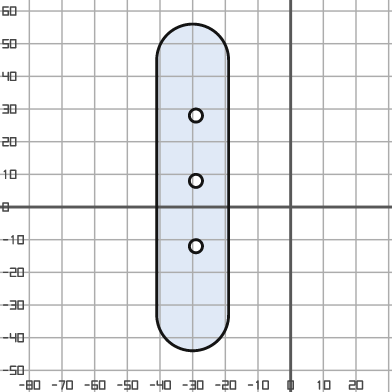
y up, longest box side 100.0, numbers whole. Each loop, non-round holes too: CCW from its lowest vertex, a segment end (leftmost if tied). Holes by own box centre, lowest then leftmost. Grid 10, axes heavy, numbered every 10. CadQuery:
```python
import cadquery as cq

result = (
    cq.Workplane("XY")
    .moveTo(-41.0, -33.0)
    .threePointArc((-30.0, -44.0), (-19.0, -33.0))
    .lineTo(-19.0, 45.0)
    .threePointArc((-30.0, 56.0), (-41.0, 45.0))
    .close()
    .moveTo(-29.0, -12.0)
    .circle(2.0)
    .moveTo(-29.0, 8.0)
    .circle(2.0)
    .moveTo(-29.0, 28.0)
    .circle(2.0)
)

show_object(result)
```